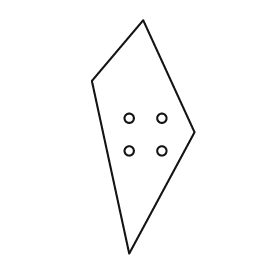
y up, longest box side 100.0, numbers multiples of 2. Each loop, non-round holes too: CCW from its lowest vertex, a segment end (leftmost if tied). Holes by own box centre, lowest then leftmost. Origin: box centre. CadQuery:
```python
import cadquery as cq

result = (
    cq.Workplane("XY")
    .moveTo(-6.0, -50.0)
    .lineTo(22.0, 2.0)
    .lineTo(0.0, 50.0)
    .lineTo(-22.0, 24.0)
    .close()
    .moveTo(-6.0, -6.0)
    .circle(2.0)
    .moveTo(8.0, -6.0)
    .circle(2.0)
    .moveTo(-6.0, 8.0)
    .circle(2.0)
    .moveTo(8.0, 8.0)
    .circle(2.0)
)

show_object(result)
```